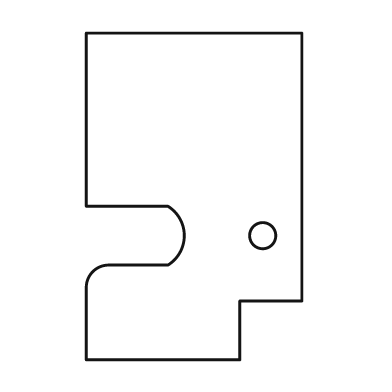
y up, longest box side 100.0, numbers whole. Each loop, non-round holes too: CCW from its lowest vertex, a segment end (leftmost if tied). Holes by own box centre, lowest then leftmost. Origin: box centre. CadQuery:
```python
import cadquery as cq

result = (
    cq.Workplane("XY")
    .moveTo(-33.0, -50.0)
    .lineTo(14.0, -50.0)
    .lineTo(14.0, -32.0)
    .lineTo(33.0, -32.0)
    .lineTo(33.0, 50.0)
    .lineTo(-33.0, 50.0)
    .lineTo(-33.0, -3.0)
    .lineTo(-8.0, -3.0)
    .threePointArc((-3.0, -12.0), (-8.0, -21.0))
    .lineTo(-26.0, -21.0)
    .threePointArc((-31.0, -23.0), (-33.0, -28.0))
    .close()
    .moveTo(21.0, -12.0)
    .circle(4.0)
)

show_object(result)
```